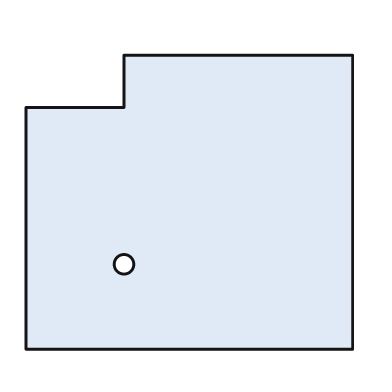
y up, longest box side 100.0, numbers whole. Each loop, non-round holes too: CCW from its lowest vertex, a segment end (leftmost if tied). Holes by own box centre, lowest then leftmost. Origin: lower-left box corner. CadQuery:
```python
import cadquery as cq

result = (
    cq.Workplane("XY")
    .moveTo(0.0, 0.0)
    .lineTo(100.0, 0.0)
    .lineTo(100.0, 90.0)
    .lineTo(30.0, 90.0)
    .lineTo(30.0, 74.0)
    .lineTo(0.0, 74.0)
    .close()
    .moveTo(30.0, 26.0)
    .circle(3.0)
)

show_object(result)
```